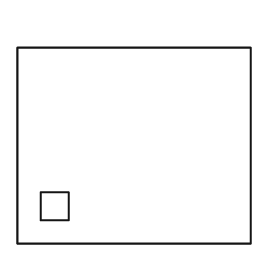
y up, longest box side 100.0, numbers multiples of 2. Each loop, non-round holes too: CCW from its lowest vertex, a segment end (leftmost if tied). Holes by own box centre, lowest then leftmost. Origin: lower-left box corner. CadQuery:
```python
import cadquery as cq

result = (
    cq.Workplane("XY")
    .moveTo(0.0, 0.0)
    .lineTo(100.0, 0.0)
    .lineTo(100.0, 84.0)
    .lineTo(0.0, 84.0)
    .close()
    .moveTo(10.0, 10.0)
    .lineTo(22.0, 10.0)
    .lineTo(22.0, 22.0)
    .lineTo(10.0, 22.0)
    .close()
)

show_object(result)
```